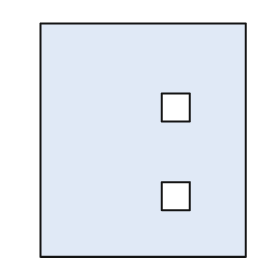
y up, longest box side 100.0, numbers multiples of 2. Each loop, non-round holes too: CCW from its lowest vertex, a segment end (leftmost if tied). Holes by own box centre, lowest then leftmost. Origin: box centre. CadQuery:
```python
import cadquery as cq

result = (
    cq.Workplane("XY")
    .moveTo(-44.0, -50.0)
    .lineTo(44.0, -50.0)
    .lineTo(44.0, 50.0)
    .lineTo(-44.0, 50.0)
    .close()
    .moveTo(8.0, -30.0)
    .lineTo(20.0, -30.0)
    .lineTo(20.0, -18.0)
    .lineTo(8.0, -18.0)
    .close()
    .moveTo(8.0, 8.0)
    .lineTo(20.0, 8.0)
    .lineTo(20.0, 20.0)
    .lineTo(8.0, 20.0)
    .close()
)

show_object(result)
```